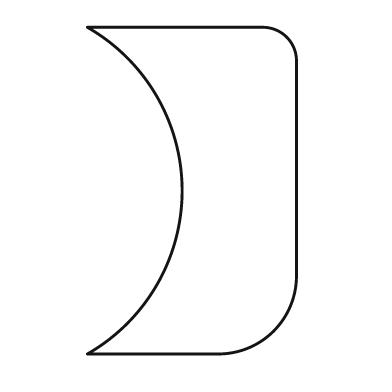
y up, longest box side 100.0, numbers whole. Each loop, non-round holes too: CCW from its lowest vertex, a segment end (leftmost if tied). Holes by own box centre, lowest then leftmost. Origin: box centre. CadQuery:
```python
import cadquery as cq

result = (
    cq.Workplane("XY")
    .moveTo(-32.0, -50.0)
    .lineTo(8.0, -50.0)
    .threePointArc((25.0, -43.0), (32.0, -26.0))
    .lineTo(32.0, 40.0)
    .threePointArc((29.0, 47.0), (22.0, 50.0))
    .lineTo(-32.0, 50.0)
    .threePointArc((-3.0, 0.0), (-32.0, -50.0))
    .close()
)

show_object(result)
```